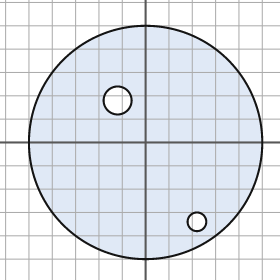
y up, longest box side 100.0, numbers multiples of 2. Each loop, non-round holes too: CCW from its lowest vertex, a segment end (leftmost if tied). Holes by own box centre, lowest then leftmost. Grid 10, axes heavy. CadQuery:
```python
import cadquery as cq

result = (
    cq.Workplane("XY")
    .moveTo(0.0, 0.0)
    .circle(50.0)
    .moveTo(22.0, -34.0)
    .circle(4.0)
    .moveTo(-12.0, 18.0)
    .circle(6.0)
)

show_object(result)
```